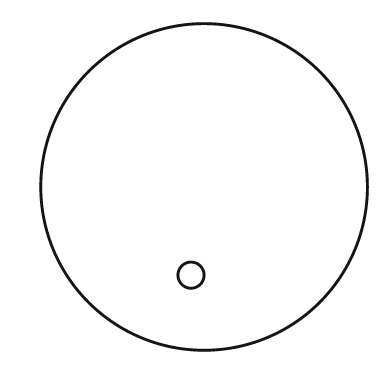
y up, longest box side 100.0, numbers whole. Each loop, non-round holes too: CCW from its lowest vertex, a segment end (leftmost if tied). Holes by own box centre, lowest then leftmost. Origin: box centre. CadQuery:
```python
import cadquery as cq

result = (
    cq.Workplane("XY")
    .moveTo(0.0, 0.0)
    .circle(50.0)
    .moveTo(-4.0, -27.0)
    .circle(4.0)
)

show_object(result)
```